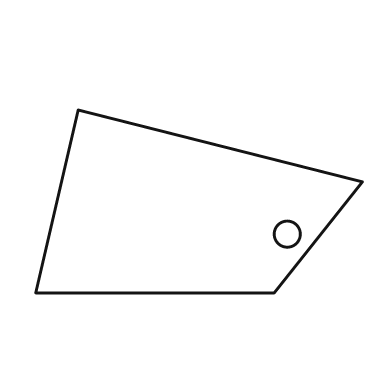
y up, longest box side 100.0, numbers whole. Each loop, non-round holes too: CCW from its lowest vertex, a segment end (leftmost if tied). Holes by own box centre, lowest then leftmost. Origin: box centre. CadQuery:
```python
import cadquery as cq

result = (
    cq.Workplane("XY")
    .moveTo(-50.0, -28.0)
    .lineTo(23.0, -28.0)
    .lineTo(50.0, 6.0)
    .lineTo(-37.0, 28.0)
    .close()
    .moveTo(27.0, -10.0)
    .circle(4.0)
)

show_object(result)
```